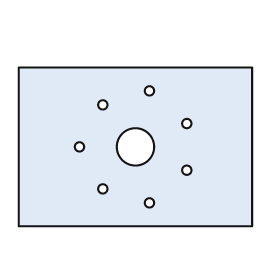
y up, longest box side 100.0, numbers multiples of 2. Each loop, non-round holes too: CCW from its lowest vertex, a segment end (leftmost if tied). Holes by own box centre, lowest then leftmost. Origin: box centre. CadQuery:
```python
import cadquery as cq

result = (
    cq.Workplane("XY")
    .moveTo(-50.0, -34.0)
    .lineTo(50.0, -34.0)
    .lineTo(50.0, 34.0)
    .lineTo(-50.0, 34.0)
    .close()
    .moveTo(6.0, -24.0)
    .circle(2.0)
    .moveTo(-14.0, -18.0)
    .circle(2.0)
    .moveTo(22.0, -10.0)
    .circle(2.0)
    .moveTo(-24.0, 0.0)
    .circle(2.0)
    .moveTo(0.0, 0.0)
    .circle(8.0)
    .moveTo(22.0, 10.0)
    .circle(2.0)
    .moveTo(-14.0, 18.0)
    .circle(2.0)
    .moveTo(6.0, 24.0)
    .circle(2.0)
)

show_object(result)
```